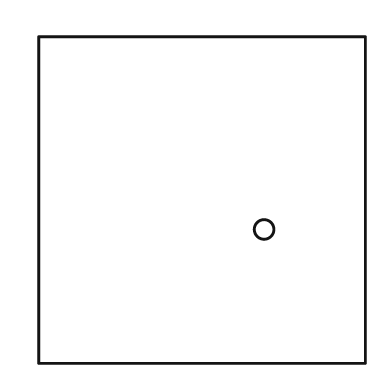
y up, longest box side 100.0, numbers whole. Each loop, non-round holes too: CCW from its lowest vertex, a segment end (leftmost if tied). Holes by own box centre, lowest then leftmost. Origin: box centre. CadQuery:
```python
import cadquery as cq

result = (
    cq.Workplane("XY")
    .moveTo(-50.0, -50.0)
    .lineTo(50.0, -50.0)
    .lineTo(50.0, 50.0)
    .lineTo(-50.0, 50.0)
    .close()
    .moveTo(19.0, -9.0)
    .circle(3.0)
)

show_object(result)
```